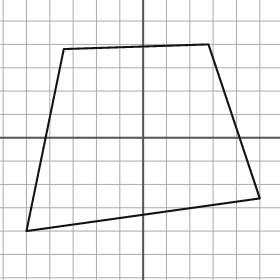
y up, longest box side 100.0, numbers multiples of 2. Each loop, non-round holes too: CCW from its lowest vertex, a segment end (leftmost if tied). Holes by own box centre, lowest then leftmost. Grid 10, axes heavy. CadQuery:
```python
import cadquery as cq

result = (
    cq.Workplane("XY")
    .moveTo(-50.0, -40.0)
    .lineTo(50.0, -26.0)
    .lineTo(28.0, 40.0)
    .lineTo(-34.0, 38.0)
    .close()
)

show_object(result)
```